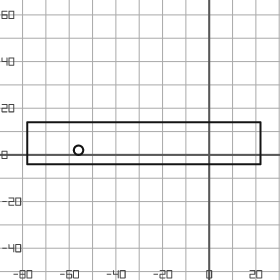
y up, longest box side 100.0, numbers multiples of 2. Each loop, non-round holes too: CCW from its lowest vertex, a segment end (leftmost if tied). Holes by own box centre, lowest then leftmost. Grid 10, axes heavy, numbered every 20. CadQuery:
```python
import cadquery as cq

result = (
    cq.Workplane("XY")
    .moveTo(-78.0, -4.0)
    .lineTo(22.0, -4.0)
    .lineTo(22.0, 14.0)
    .lineTo(-78.0, 14.0)
    .close()
    .moveTo(-56.0, 2.0)
    .circle(2.0)
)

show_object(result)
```